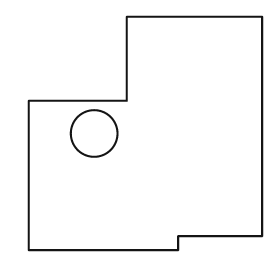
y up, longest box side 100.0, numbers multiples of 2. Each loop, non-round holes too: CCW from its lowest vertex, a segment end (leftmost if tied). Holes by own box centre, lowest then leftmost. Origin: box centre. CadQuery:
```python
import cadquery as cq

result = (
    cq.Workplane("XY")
    .moveTo(-50.0, -50.0)
    .lineTo(14.0, -50.0)
    .lineTo(14.0, -44.0)
    .lineTo(50.0, -44.0)
    .lineTo(50.0, 50.0)
    .lineTo(-8.0, 50.0)
    .lineTo(-8.0, 14.0)
    .lineTo(-50.0, 14.0)
    .close()
    .moveTo(-22.0, 0.0)
    .circle(10.0)
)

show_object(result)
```